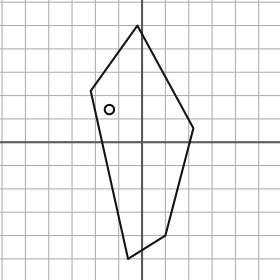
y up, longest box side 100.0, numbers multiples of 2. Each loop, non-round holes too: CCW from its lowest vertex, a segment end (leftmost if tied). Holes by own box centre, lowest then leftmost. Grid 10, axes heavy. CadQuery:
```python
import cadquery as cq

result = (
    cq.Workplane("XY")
    .moveTo(-6.0, -50.0)
    .lineTo(10.0, -40.0)
    .lineTo(22.0, 6.0)
    .lineTo(-2.0, 50.0)
    .lineTo(-22.0, 22.0)
    .close()
    .moveTo(-14.0, 14.0)
    .circle(2.0)
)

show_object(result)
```